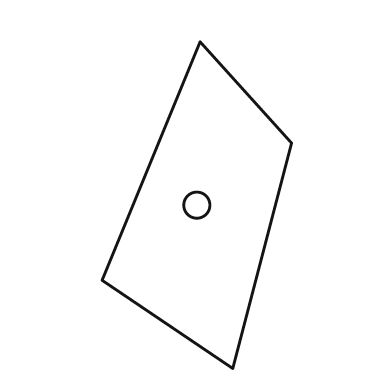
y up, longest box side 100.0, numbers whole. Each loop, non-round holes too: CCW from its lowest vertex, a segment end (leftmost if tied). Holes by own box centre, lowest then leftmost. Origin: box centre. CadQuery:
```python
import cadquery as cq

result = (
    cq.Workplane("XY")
    .moveTo(11.0, -50.0)
    .lineTo(29.0, 19.0)
    .lineTo(1.0, 50.0)
    .lineTo(-29.0, -23.0)
    .close()
    .moveTo(0.0, 0.0)
    .circle(4.0)
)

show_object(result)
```